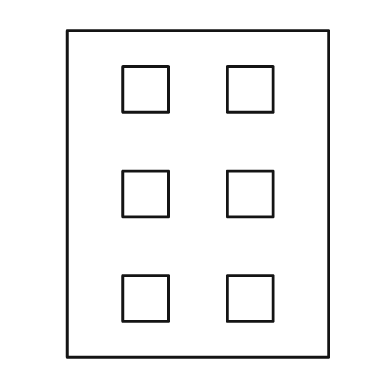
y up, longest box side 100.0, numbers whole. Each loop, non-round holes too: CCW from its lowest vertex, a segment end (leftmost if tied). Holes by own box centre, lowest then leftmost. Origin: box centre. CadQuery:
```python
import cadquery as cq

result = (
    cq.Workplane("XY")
    .moveTo(-40.0, -50.0)
    .lineTo(40.0, -50.0)
    .lineTo(40.0, 50.0)
    .lineTo(-40.0, 50.0)
    .close()
    .moveTo(-23.0, -39.0)
    .lineTo(-9.0, -39.0)
    .lineTo(-9.0, -25.0)
    .lineTo(-23.0, -25.0)
    .close()
    .moveTo(9.0, -39.0)
    .lineTo(23.0, -39.0)
    .lineTo(23.0, -25.0)
    .lineTo(9.0, -25.0)
    .close()
    .moveTo(-23.0, -7.0)
    .lineTo(-9.0, -7.0)
    .lineTo(-9.0, 7.0)
    .lineTo(-23.0, 7.0)
    .close()
    .moveTo(9.0, -7.0)
    .lineTo(23.0, -7.0)
    .lineTo(23.0, 7.0)
    .lineTo(9.0, 7.0)
    .close()
    .moveTo(-23.0, 25.0)
    .lineTo(-9.0, 25.0)
    .lineTo(-9.0, 39.0)
    .lineTo(-23.0, 39.0)
    .close()
    .moveTo(9.0, 25.0)
    .lineTo(23.0, 25.0)
    .lineTo(23.0, 39.0)
    .lineTo(9.0, 39.0)
    .close()
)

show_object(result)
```